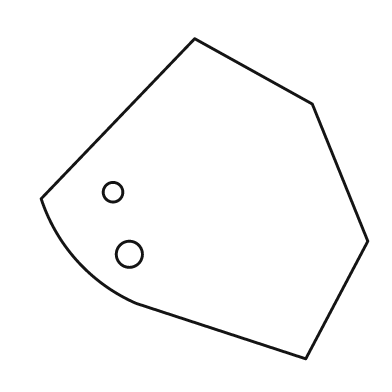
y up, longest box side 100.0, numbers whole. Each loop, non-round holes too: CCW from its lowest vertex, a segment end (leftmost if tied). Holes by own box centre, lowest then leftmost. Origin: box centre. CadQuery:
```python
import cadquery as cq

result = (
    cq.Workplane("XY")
    .moveTo(31.0, -49.0)
    .lineTo(50.0, -13.0)
    .lineTo(33.0, 29.0)
    .lineTo(-3.0, 49.0)
    .lineTo(-50.0, 0.0)
    .threePointArc((-39.0, -19.0), (-21.0, -32.0))
    .close()
    .moveTo(-23.0, -17.0)
    .circle(4.0)
    .moveTo(-28.0, 2.0)
    .circle(3.0)
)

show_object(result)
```